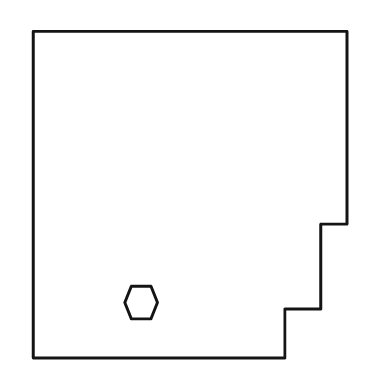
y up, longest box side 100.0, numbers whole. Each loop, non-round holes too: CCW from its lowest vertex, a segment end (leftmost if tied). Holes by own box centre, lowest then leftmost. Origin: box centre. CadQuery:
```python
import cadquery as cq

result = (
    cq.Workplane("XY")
    .moveTo(-48.0, -50.0)
    .lineTo(29.0, -50.0)
    .lineTo(29.0, -35.0)
    .lineTo(40.0, -35.0)
    .lineTo(40.0, -9.0)
    .lineTo(48.0, -9.0)
    .lineTo(48.0, 50.0)
    .lineTo(-48.0, 50.0)
    .close()
    .moveTo(-18.0, -38.0)
    .lineTo(-12.0, -38.0)
    .lineTo(-10.0, -33.0)
    .lineTo(-12.0, -28.0)
    .lineTo(-18.0, -28.0)
    .lineTo(-20.0, -33.0)
    .close()
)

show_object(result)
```